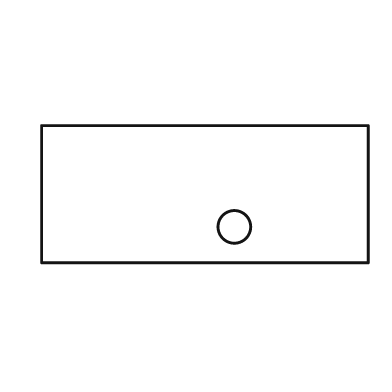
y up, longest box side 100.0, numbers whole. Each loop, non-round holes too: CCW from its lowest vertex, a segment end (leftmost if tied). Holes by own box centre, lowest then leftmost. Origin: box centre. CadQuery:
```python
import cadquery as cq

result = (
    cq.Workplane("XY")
    .moveTo(-50.0, -21.0)
    .lineTo(50.0, -21.0)
    .lineTo(50.0, 21.0)
    .lineTo(-50.0, 21.0)
    .close()
    .moveTo(9.0, -10.0)
    .circle(5.0)
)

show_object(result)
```